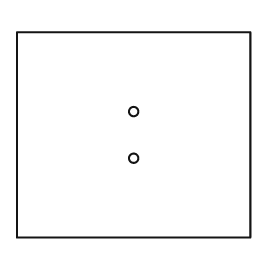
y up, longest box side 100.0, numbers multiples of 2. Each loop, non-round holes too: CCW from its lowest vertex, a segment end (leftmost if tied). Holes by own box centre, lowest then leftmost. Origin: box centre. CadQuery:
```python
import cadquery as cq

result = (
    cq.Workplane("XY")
    .moveTo(-50.0, -44.0)
    .lineTo(50.0, -44.0)
    .lineTo(50.0, 44.0)
    .lineTo(-50.0, 44.0)
    .close()
    .moveTo(0.0, -10.0)
    .circle(2.0)
    .moveTo(0.0, 10.0)
    .circle(2.0)
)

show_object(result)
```